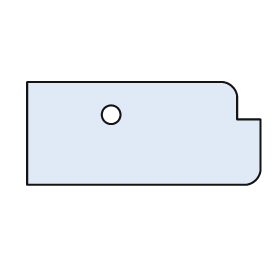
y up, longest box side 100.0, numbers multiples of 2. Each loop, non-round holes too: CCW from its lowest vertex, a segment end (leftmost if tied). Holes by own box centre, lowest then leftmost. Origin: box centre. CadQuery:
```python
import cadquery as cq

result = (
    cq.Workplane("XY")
    .moveTo(-50.0, -22.0)
    .lineTo(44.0, -22.0)
    .threePointArc((48.0, -20.0), (50.0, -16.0))
    .lineTo(50.0, 6.0)
    .lineTo(40.0, 6.0)
    .lineTo(40.0, 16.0)
    .threePointArc((38.0, 20.0), (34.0, 22.0))
    .lineTo(-50.0, 22.0)
    .close()
    .moveTo(-14.0, 8.0)
    .circle(4.0)
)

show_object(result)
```